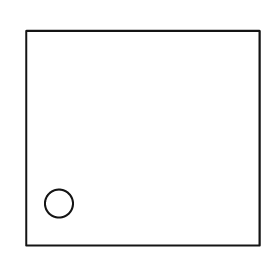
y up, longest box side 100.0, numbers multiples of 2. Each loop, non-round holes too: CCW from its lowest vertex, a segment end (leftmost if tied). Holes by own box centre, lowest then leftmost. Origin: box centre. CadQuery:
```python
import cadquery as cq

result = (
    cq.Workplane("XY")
    .moveTo(-50.0, -46.0)
    .lineTo(50.0, -46.0)
    .lineTo(50.0, 46.0)
    .lineTo(-50.0, 46.0)
    .close()
    .moveTo(-36.0, -28.0)
    .circle(6.0)
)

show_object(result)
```